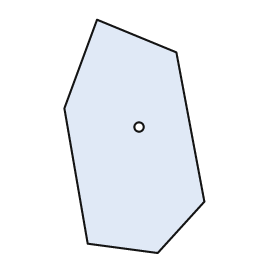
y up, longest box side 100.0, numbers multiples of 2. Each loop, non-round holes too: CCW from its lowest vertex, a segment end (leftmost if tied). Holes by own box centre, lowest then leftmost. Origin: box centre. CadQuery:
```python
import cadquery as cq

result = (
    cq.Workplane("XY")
    .moveTo(10.0, -50.0)
    .lineTo(30.0, -28.0)
    .lineTo(18.0, 36.0)
    .lineTo(-16.0, 50.0)
    .lineTo(-30.0, 12.0)
    .lineTo(-20.0, -46.0)
    .close()
    .moveTo(2.0, 4.0)
    .circle(2.0)
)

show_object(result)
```